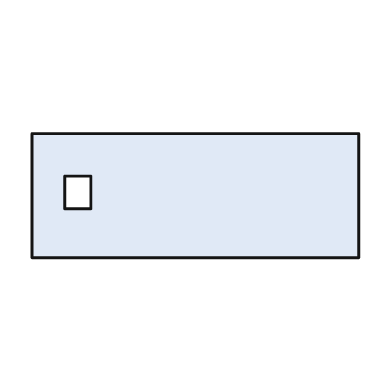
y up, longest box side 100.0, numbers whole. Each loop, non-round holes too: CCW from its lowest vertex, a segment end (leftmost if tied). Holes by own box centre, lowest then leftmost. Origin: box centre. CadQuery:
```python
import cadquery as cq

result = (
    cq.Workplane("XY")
    .moveTo(-50.0, -19.0)
    .lineTo(50.0, -19.0)
    .lineTo(50.0, 19.0)
    .lineTo(-50.0, 19.0)
    .close()
    .moveTo(-40.0, -4.0)
    .lineTo(-32.0, -4.0)
    .lineTo(-32.0, 6.0)
    .lineTo(-40.0, 6.0)
    .close()
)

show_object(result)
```